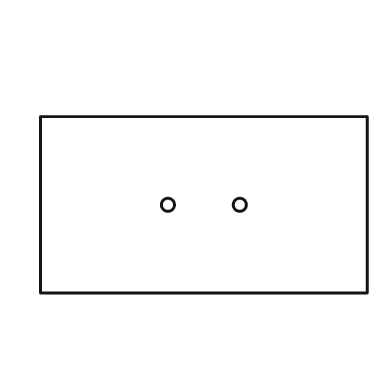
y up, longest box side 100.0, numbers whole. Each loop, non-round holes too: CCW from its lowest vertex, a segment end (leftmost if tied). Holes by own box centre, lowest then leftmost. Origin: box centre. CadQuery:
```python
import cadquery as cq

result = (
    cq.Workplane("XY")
    .moveTo(-50.0, -27.0)
    .lineTo(50.0, -27.0)
    .lineTo(50.0, 27.0)
    .lineTo(-50.0, 27.0)
    .close()
    .moveTo(-11.0, 0.0)
    .circle(2.0)
    .moveTo(11.0, 0.0)
    .circle(2.0)
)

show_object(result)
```